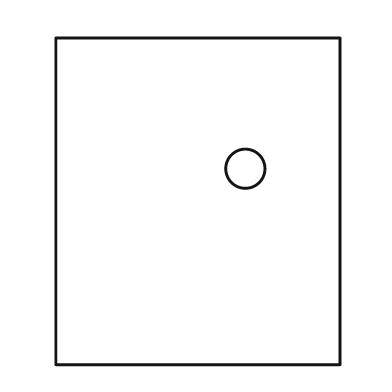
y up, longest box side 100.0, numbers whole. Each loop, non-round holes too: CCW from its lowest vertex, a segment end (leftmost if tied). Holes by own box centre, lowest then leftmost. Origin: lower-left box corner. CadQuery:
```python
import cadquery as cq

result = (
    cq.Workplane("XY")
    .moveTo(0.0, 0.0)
    .lineTo(87.0, 0.0)
    .lineTo(87.0, 100.0)
    .lineTo(0.0, 100.0)
    .close()
    .moveTo(58.0, 60.0)
    .circle(6.0)
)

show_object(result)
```